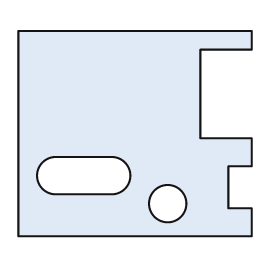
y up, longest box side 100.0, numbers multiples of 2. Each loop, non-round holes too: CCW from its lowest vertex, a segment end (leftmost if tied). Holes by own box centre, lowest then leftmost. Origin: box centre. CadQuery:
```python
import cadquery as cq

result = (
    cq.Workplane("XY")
    .moveTo(-50.0, -44.0)
    .lineTo(50.0, -44.0)
    .lineTo(50.0, -32.0)
    .lineTo(40.0, -32.0)
    .lineTo(40.0, -14.0)
    .lineTo(50.0, -14.0)
    .lineTo(50.0, -2.0)
    .lineTo(28.0, -2.0)
    .lineTo(28.0, 36.0)
    .lineTo(50.0, 36.0)
    .lineTo(50.0, 44.0)
    .lineTo(-50.0, 44.0)
    .close()
    .moveTo(14.0, -30.0)
    .circle(8.0)
    .moveTo(-34.0, -26.0)
    .lineTo(-10.0, -26.0)
    .threePointArc((-2.0, -18.0), (-10.0, -10.0))
    .lineTo(-34.0, -10.0)
    .threePointArc((-42.0, -18.0), (-34.0, -26.0))
    .close()
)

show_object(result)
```